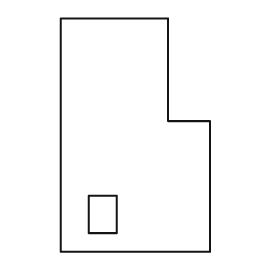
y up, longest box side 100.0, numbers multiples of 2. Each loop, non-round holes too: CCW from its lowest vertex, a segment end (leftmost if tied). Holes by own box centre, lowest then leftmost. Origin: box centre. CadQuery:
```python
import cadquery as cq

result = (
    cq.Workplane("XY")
    .moveTo(-32.0, -50.0)
    .lineTo(32.0, -50.0)
    .lineTo(32.0, 6.0)
    .lineTo(14.0, 6.0)
    .lineTo(14.0, 50.0)
    .lineTo(-32.0, 50.0)
    .close()
    .moveTo(-20.0, -42.0)
    .lineTo(-8.0, -42.0)
    .lineTo(-8.0, -26.0)
    .lineTo(-20.0, -26.0)
    .close()
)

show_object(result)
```